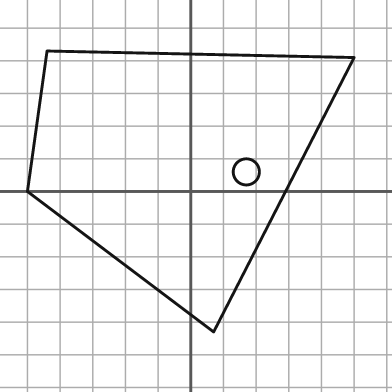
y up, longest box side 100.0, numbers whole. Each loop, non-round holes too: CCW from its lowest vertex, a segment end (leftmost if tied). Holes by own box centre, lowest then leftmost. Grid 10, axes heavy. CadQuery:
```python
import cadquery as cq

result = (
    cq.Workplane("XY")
    .moveTo(7.0, -43.0)
    .lineTo(50.0, 41.0)
    .lineTo(-44.0, 43.0)
    .lineTo(-50.0, 0.0)
    .close()
    .moveTo(17.0, 6.0)
    .circle(4.0)
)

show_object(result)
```